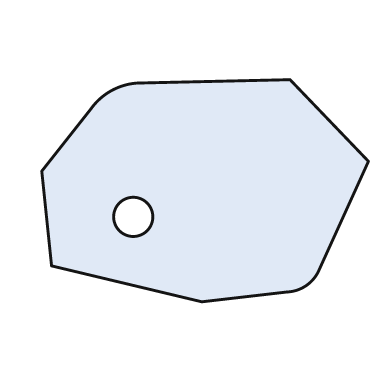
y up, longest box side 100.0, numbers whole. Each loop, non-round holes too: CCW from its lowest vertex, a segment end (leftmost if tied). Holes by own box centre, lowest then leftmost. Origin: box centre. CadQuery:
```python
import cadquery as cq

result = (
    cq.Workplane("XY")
    .moveTo(-1.0, -34.0)
    .lineTo(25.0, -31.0)
    .threePointArc((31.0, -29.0), (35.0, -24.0))
    .lineTo(50.0, 9.0)
    .lineTo(26.0, 34.0)
    .lineTo(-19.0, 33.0)
    .threePointArc((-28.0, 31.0), (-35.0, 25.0))
    .lineTo(-50.0, 6.0)
    .lineTo(-47.0, -23.0)
    .close()
    .moveTo(-22.0, -8.0)
    .circle(6.0)
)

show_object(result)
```